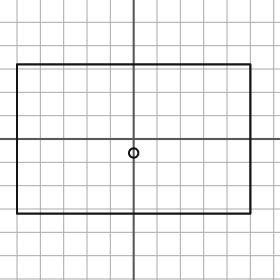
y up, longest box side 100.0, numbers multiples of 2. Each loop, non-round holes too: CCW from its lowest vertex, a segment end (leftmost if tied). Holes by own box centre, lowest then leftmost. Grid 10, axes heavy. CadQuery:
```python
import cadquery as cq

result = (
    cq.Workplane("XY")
    .moveTo(-50.0, -32.0)
    .lineTo(50.0, -32.0)
    .lineTo(50.0, 32.0)
    .lineTo(-50.0, 32.0)
    .close()
    .moveTo(0.0, -6.0)
    .circle(2.0)
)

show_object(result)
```